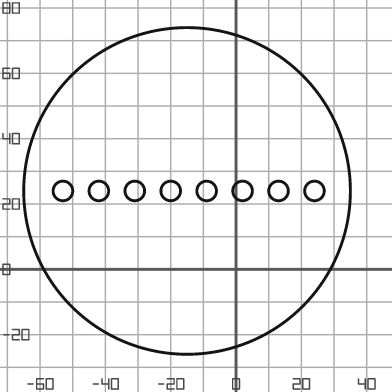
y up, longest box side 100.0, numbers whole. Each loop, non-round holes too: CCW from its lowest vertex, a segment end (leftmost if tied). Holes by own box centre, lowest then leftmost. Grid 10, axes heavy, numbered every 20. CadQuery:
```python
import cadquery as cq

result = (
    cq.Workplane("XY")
    .moveTo(-15.0, 24.0)
    .circle(50.0)
    .moveTo(-53.0, 24.0)
    .circle(3.0)
    .moveTo(-42.0, 24.0)
    .circle(3.0)
    .moveTo(-31.0, 24.0)
    .circle(3.0)
    .moveTo(-20.0, 24.0)
    .circle(3.0)
    .moveTo(-9.0, 24.0)
    .circle(3.0)
    .moveTo(2.0, 24.0)
    .circle(3.0)
    .moveTo(13.0, 24.0)
    .circle(3.0)
    .moveTo(24.0, 24.0)
    .circle(3.0)
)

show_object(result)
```